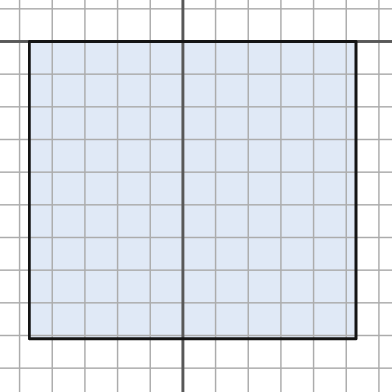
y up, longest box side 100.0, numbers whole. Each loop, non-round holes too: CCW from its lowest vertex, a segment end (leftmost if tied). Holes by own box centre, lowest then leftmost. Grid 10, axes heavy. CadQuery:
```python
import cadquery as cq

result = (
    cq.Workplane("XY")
    .moveTo(-47.0, -91.0)
    .lineTo(53.0, -91.0)
    .lineTo(53.0, 0.0)
    .lineTo(-47.0, 0.0)
    .close()
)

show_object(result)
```